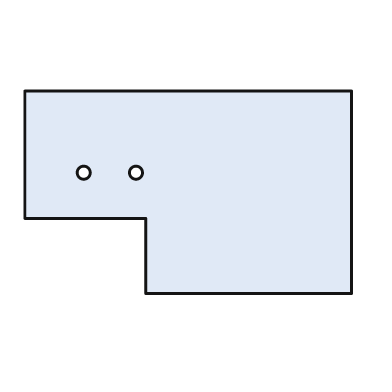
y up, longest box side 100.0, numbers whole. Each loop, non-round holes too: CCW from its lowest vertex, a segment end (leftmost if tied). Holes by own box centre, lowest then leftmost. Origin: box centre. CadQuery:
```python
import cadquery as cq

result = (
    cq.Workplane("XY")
    .moveTo(-13.0, -31.0)
    .lineTo(50.0, -31.0)
    .lineTo(50.0, 31.0)
    .lineTo(-50.0, 31.0)
    .lineTo(-50.0, -8.0)
    .lineTo(-13.0, -8.0)
    .close()
    .moveTo(-32.0, 6.0)
    .circle(2.0)
    .moveTo(-16.0, 6.0)
    .circle(2.0)
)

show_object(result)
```